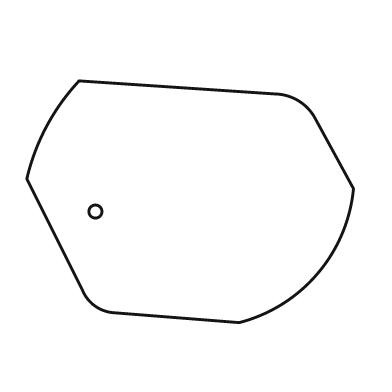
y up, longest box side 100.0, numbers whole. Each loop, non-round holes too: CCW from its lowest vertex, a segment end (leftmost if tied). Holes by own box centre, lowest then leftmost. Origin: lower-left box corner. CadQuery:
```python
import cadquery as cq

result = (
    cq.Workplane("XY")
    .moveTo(65.0, 0.0)
    .threePointArc((89.0, 15.0), (100.0, 41.0))
    .lineTo(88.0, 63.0)
    .threePointArc((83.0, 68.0), (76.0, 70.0))
    .lineTo(16.0, 74.0)
    .threePointArc((6.0, 60.0), (0.0, 44.0))
    .lineTo(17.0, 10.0)
    .threePointArc((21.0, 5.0), (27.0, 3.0))
    .close()
    .moveTo(21.0, 34.0)
    .circle(2.0)
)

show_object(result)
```